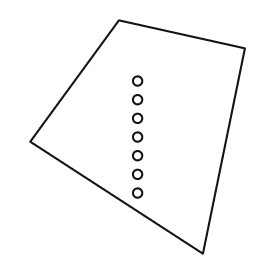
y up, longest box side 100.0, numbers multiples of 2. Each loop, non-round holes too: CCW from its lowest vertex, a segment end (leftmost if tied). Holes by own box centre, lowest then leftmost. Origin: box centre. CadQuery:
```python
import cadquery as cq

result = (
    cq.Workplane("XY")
    .moveTo(28.0, -50.0)
    .lineTo(46.0, 38.0)
    .lineTo(-8.0, 50.0)
    .lineTo(-46.0, -2.0)
    .close()
    .moveTo(0.0, -24.0)
    .circle(2.0)
    .moveTo(0.0, -16.0)
    .circle(2.0)
    .moveTo(0.0, -8.0)
    .circle(2.0)
    .moveTo(0.0, 0.0)
    .circle(2.0)
    .moveTo(0.0, 8.0)
    .circle(2.0)
    .moveTo(0.0, 16.0)
    .circle(2.0)
    .moveTo(0.0, 24.0)
    .circle(2.0)
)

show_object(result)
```